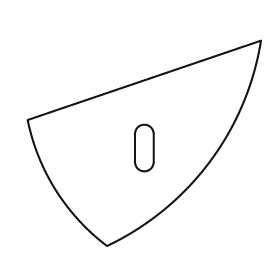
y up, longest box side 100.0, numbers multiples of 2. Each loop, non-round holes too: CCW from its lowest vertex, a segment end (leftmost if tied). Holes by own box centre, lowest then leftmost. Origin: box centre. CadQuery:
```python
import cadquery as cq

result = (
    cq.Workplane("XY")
    .moveTo(-16.0, -44.0)
    .threePointArc((28.0, -8.0), (50.0, 44.0))
    .lineTo(-50.0, 10.0)
    .threePointArc((-38.0, -20.0), (-16.0, -44.0))
    .close()
    .moveTo(-4.0, -8.0)
    .threePointArc((0.0, -12.0), (4.0, -8.0))
    .lineTo(4.0, 4.0)
    .threePointArc((0.0, 8.0), (-4.0, 4.0))
    .close()
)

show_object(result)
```